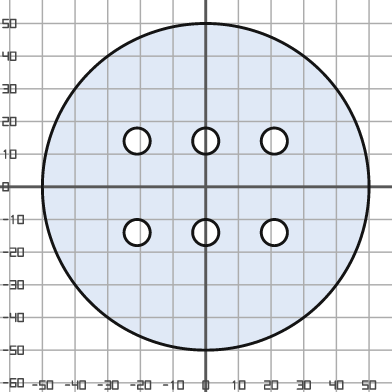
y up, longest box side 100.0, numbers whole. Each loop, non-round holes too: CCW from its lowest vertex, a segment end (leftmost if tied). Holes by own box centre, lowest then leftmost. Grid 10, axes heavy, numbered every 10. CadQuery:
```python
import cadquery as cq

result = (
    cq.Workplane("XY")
    .moveTo(0.0, 0.0)
    .circle(50.0)
    .moveTo(-21.0, -14.0)
    .circle(4.0)
    .moveTo(0.0, -14.0)
    .circle(4.0)
    .moveTo(21.0, -14.0)
    .circle(4.0)
    .moveTo(-21.0, 14.0)
    .circle(4.0)
    .moveTo(0.0, 14.0)
    .circle(4.0)
    .moveTo(21.0, 14.0)
    .circle(4.0)
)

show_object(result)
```